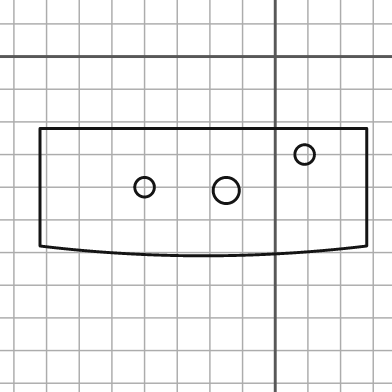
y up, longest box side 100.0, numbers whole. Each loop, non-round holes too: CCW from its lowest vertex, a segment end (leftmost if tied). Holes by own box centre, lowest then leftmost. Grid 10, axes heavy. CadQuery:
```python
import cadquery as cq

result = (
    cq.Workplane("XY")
    .moveTo(-72.0, -58.0)
    .threePointArc((-22.0, -61.0), (28.0, -58.0))
    .lineTo(28.0, -22.0)
    .lineTo(-72.0, -22.0)
    .close()
    .moveTo(-15.0, -41.0)
    .circle(4.0)
    .moveTo(-40.0, -40.0)
    .circle(3.0)
    .moveTo(9.0, -30.0)
    .circle(3.0)
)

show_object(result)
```